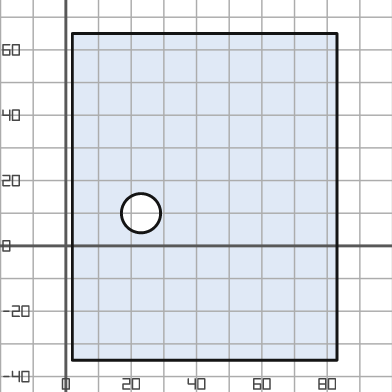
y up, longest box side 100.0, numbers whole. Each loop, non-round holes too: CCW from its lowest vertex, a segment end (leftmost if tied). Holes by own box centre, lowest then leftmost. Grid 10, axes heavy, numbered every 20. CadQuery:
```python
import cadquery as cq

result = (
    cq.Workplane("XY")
    .moveTo(2.0, -35.0)
    .lineTo(83.0, -35.0)
    .lineTo(83.0, 65.0)
    .lineTo(2.0, 65.0)
    .close()
    .moveTo(23.0, 10.0)
    .circle(6.0)
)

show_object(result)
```